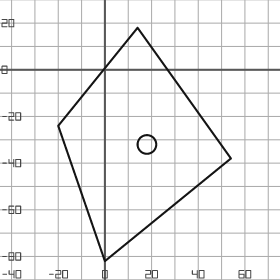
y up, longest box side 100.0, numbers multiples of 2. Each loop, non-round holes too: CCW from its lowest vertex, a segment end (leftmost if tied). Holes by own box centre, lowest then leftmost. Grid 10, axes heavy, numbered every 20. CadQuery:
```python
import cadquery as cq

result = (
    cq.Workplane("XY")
    .moveTo(0.0, -82.0)
    .lineTo(54.0, -38.0)
    .lineTo(14.0, 18.0)
    .lineTo(-20.0, -24.0)
    .close()
    .moveTo(18.0, -32.0)
    .circle(4.0)
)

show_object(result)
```